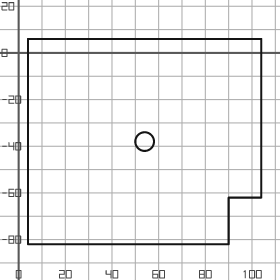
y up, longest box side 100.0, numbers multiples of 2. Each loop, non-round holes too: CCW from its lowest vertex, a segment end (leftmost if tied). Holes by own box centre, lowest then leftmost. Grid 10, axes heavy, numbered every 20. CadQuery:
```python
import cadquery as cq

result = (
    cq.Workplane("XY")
    .moveTo(4.0, -82.0)
    .lineTo(90.0, -82.0)
    .lineTo(90.0, -62.0)
    .lineTo(104.0, -62.0)
    .lineTo(104.0, 6.0)
    .lineTo(4.0, 6.0)
    .close()
    .moveTo(54.0, -38.0)
    .circle(4.0)
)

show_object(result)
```